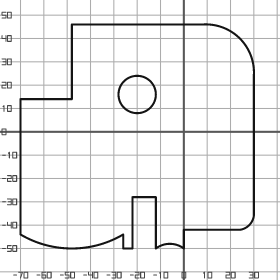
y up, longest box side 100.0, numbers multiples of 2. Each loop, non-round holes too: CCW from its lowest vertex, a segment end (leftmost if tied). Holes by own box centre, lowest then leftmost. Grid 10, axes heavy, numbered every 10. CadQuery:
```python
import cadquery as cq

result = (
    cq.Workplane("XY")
    .moveTo(-26.0, -50.0)
    .lineTo(-22.0, -50.0)
    .lineTo(-22.0, -28.0)
    .lineTo(-12.0, -28.0)
    .lineTo(-12.0, -50.0)
    .threePointArc((-6.0, -48.0), (0.0, -50.0))
    .lineTo(0.0, -42.0)
    .lineTo(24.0, -42.0)
    .threePointArc((28.0, -40.0), (30.0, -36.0))
    .lineTo(30.0, 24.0)
    .threePointArc((24.0, 40.0), (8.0, 46.0))
    .lineTo(-48.0, 46.0)
    .lineTo(-48.0, 14.0)
    .lineTo(-70.0, 14.0)
    .lineTo(-70.0, -44.0)
    .threePointArc((-48.0, -50.0), (-26.0, -44.0))
    .close()
    .moveTo(-20.0, 16.0)
    .circle(8.0)
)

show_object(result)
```